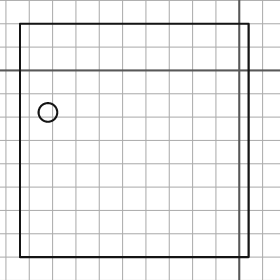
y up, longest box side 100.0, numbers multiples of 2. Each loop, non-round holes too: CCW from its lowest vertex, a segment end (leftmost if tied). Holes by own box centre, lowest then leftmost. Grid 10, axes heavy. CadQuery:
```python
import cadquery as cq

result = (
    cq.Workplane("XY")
    .moveTo(-94.0, -80.0)
    .lineTo(4.0, -80.0)
    .lineTo(4.0, 20.0)
    .lineTo(-94.0, 20.0)
    .close()
    .moveTo(-82.0, -18.0)
    .circle(4.0)
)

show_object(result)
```